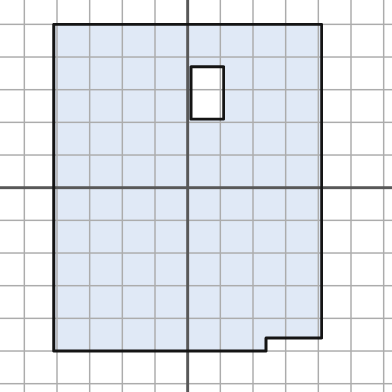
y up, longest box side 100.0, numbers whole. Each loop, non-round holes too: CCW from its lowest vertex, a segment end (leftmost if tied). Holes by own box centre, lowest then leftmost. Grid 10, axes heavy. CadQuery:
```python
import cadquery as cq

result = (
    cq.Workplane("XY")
    .moveTo(-41.0, -50.0)
    .lineTo(24.0, -50.0)
    .lineTo(24.0, -46.0)
    .lineTo(41.0, -46.0)
    .lineTo(41.0, 50.0)
    .lineTo(-41.0, 50.0)
    .close()
    .moveTo(1.0, 21.0)
    .lineTo(11.0, 21.0)
    .lineTo(11.0, 37.0)
    .lineTo(1.0, 37.0)
    .close()
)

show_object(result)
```